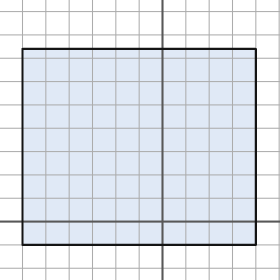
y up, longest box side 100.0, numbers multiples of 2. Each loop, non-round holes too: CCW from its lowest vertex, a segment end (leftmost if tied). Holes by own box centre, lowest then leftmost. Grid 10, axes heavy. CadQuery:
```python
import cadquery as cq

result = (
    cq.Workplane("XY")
    .moveTo(-60.0, -10.0)
    .lineTo(40.0, -10.0)
    .lineTo(40.0, 74.0)
    .lineTo(-60.0, 74.0)
    .close()
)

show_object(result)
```